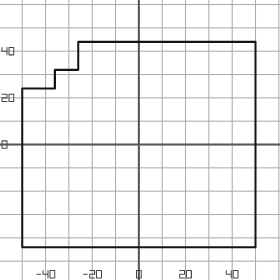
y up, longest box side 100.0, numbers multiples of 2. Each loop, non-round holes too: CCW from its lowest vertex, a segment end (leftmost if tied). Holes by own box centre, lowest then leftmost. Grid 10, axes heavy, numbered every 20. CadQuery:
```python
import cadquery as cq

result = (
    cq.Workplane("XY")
    .moveTo(-50.0, -44.0)
    .lineTo(50.0, -44.0)
    .lineTo(50.0, 44.0)
    .lineTo(-26.0, 44.0)
    .lineTo(-26.0, 32.0)
    .lineTo(-36.0, 32.0)
    .lineTo(-36.0, 24.0)
    .lineTo(-50.0, 24.0)
    .close()
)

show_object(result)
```